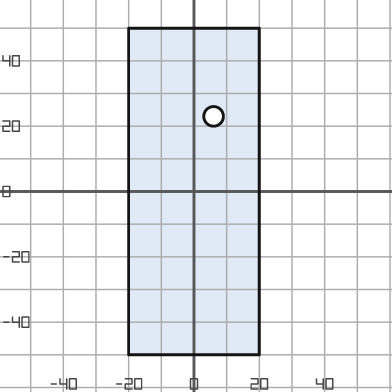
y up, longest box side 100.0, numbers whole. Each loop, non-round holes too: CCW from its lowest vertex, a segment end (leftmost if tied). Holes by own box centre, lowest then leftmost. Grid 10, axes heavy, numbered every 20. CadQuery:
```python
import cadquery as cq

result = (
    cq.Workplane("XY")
    .moveTo(-20.0, -50.0)
    .lineTo(20.0, -50.0)
    .lineTo(20.0, 50.0)
    .lineTo(-20.0, 50.0)
    .close()
    .moveTo(6.0, 23.0)
    .circle(3.0)
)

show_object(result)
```